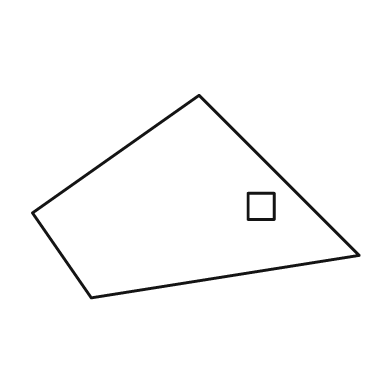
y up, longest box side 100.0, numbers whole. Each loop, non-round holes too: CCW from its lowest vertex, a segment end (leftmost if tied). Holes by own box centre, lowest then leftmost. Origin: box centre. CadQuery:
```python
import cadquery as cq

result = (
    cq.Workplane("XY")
    .moveTo(-32.0, -31.0)
    .lineTo(50.0, -18.0)
    .lineTo(1.0, 31.0)
    .lineTo(-50.0, -5.0)
    .close()
    .moveTo(16.0, -7.0)
    .lineTo(24.0, -7.0)
    .lineTo(24.0, 1.0)
    .lineTo(16.0, 1.0)
    .close()
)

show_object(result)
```